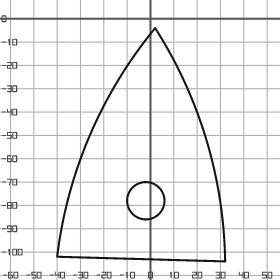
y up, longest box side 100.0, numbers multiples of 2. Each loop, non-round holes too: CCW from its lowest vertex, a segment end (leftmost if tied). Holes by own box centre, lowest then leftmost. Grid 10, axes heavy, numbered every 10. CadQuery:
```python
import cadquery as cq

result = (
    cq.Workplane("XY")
    .moveTo(32.0, -104.0)
    .threePointArc((24.0, -52.0), (2.0, -4.0))
    .threePointArc((-26.0, -50.0), (-40.0, -102.0))
    .close()
    .moveTo(-2.0, -78.0)
    .circle(8.0)
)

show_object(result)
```